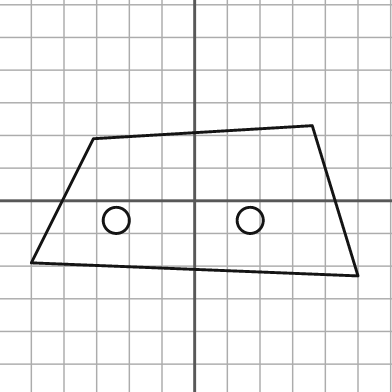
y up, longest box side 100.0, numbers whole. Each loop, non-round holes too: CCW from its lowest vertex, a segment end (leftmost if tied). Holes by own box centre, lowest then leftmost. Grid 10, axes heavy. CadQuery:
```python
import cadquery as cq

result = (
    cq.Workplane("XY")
    .moveTo(50.0, -23.0)
    .lineTo(36.0, 23.0)
    .lineTo(-31.0, 19.0)
    .lineTo(-50.0, -19.0)
    .close()
    .moveTo(-24.0, -6.0)
    .circle(4.0)
    .moveTo(17.0, -6.0)
    .circle(4.0)
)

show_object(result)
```